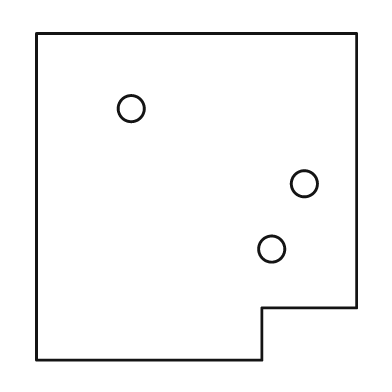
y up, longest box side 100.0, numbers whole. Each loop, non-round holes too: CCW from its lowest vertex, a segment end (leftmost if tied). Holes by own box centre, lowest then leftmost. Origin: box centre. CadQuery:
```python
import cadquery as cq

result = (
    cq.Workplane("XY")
    .moveTo(-49.0, -50.0)
    .lineTo(20.0, -50.0)
    .lineTo(20.0, -34.0)
    .lineTo(49.0, -34.0)
    .lineTo(49.0, 50.0)
    .lineTo(-49.0, 50.0)
    .close()
    .moveTo(23.0, -16.0)
    .circle(4.0)
    .moveTo(33.0, 4.0)
    .circle(4.0)
    .moveTo(-20.0, 27.0)
    .circle(4.0)
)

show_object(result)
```